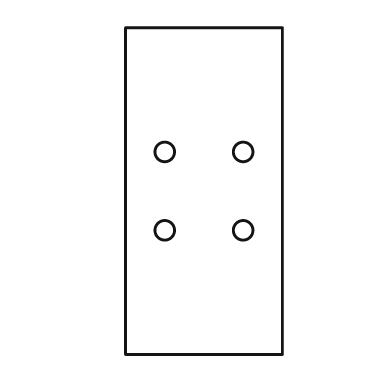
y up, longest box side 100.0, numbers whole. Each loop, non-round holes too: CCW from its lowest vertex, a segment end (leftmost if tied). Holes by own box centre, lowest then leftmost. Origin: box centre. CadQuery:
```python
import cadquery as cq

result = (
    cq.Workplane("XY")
    .moveTo(-24.0, -50.0)
    .lineTo(24.0, -50.0)
    .lineTo(24.0, 50.0)
    .lineTo(-24.0, 50.0)
    .close()
    .moveTo(-12.0, -12.0)
    .circle(3.0)
    .moveTo(12.0, -12.0)
    .circle(3.0)
    .moveTo(-12.0, 12.0)
    .circle(3.0)
    .moveTo(12.0, 12.0)
    .circle(3.0)
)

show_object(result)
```